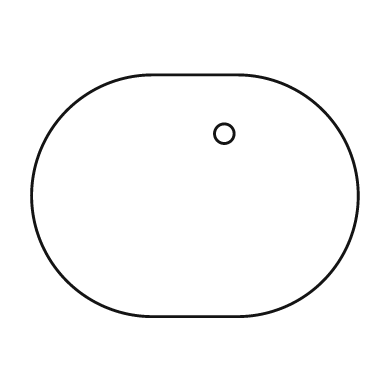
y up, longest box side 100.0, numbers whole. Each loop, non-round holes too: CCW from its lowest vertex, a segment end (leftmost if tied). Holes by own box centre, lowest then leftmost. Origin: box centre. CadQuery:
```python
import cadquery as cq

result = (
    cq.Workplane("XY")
    .moveTo(-13.0, -37.0)
    .lineTo(13.0, -37.0)
    .threePointArc((50.0, 0.0), (13.0, 37.0))
    .lineTo(-13.0, 37.0)
    .threePointArc((-50.0, 0.0), (-13.0, -37.0))
    .close()
    .moveTo(9.0, 19.0)
    .circle(3.0)
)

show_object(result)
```